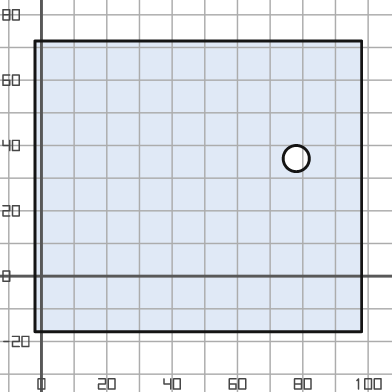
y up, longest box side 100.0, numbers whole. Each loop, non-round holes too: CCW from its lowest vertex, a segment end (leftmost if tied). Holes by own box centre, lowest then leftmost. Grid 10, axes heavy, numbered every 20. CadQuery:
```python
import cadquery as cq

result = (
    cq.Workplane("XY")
    .moveTo(-2.0, -17.0)
    .lineTo(98.0, -17.0)
    .lineTo(98.0, 72.0)
    .lineTo(-2.0, 72.0)
    .close()
    .moveTo(78.0, 36.0)
    .circle(4.0)
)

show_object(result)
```